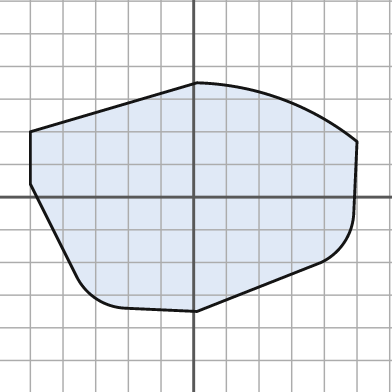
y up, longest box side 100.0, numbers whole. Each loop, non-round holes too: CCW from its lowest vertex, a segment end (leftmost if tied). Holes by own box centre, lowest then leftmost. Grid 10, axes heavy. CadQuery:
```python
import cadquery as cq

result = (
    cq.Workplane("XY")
    .moveTo(1.0, -35.0)
    .lineTo(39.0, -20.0)
    .threePointArc((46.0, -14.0), (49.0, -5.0))
    .lineTo(50.0, 17.0)
    .threePointArc((27.0, 30.0), (1.0, 35.0))
    .lineTo(-50.0, 20.0)
    .lineTo(-50.0, 4.0)
    .lineTo(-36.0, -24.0)
    .threePointArc((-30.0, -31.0), (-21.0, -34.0))
    .close()
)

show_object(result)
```